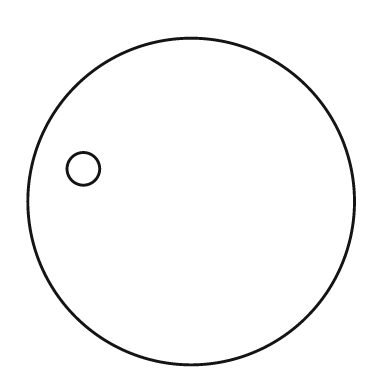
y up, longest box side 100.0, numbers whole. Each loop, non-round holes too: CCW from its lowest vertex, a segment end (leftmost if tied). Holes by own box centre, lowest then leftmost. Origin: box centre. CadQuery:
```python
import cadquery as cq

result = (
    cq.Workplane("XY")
    .moveTo(0.0, 0.0)
    .circle(50.0)
    .moveTo(-33.0, 10.0)
    .circle(5.0)
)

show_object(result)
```